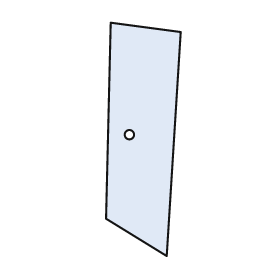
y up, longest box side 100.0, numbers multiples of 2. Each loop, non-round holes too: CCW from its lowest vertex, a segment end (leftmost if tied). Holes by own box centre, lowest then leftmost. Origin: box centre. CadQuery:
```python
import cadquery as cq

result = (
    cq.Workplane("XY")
    .moveTo(10.0, -50.0)
    .lineTo(16.0, 46.0)
    .lineTo(-14.0, 50.0)
    .lineTo(-16.0, -34.0)
    .close()
    .moveTo(-6.0, 2.0)
    .circle(2.0)
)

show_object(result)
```